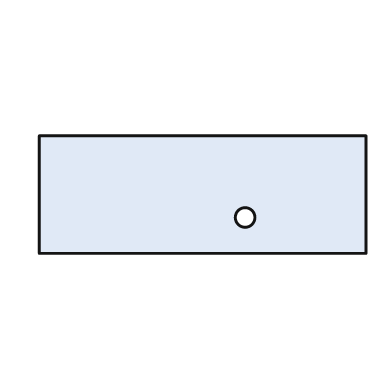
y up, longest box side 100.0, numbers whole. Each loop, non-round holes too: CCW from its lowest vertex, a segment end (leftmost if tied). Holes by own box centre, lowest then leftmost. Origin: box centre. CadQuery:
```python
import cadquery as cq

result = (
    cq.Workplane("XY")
    .moveTo(-50.0, -18.0)
    .lineTo(50.0, -18.0)
    .lineTo(50.0, 18.0)
    .lineTo(-50.0, 18.0)
    .close()
    .moveTo(13.0, -7.0)
    .circle(3.0)
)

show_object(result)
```